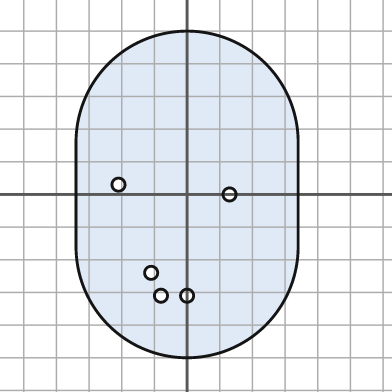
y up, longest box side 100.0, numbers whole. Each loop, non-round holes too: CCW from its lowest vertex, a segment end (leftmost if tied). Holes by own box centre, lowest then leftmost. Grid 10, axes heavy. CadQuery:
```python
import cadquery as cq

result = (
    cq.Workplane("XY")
    .moveTo(-34.0, -16.0)
    .threePointArc((0.0, -50.0), (34.0, -16.0))
    .lineTo(34.0, 16.0)
    .threePointArc((0.0, 50.0), (-34.0, 16.0))
    .close()
    .moveTo(-8.0, -31.0)
    .circle(2.0)
    .moveTo(0.0, -31.0)
    .circle(2.0)
    .moveTo(-11.0, -24.0)
    .circle(2.0)
    .moveTo(13.0, 0.0)
    .circle(2.0)
    .moveTo(-21.0, 3.0)
    .circle(2.0)
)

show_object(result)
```